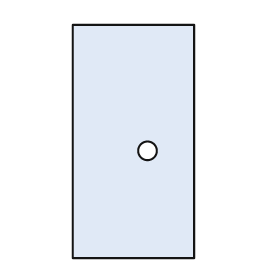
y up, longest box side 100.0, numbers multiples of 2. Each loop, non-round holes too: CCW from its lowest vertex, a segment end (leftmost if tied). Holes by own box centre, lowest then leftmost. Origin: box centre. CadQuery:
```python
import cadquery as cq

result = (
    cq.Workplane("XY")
    .moveTo(-26.0, -50.0)
    .lineTo(26.0, -50.0)
    .lineTo(26.0, 50.0)
    .lineTo(-26.0, 50.0)
    .close()
    .moveTo(6.0, -4.0)
    .circle(4.0)
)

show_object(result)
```